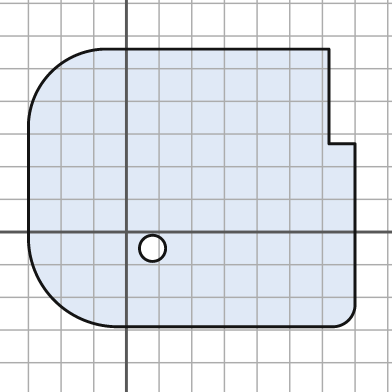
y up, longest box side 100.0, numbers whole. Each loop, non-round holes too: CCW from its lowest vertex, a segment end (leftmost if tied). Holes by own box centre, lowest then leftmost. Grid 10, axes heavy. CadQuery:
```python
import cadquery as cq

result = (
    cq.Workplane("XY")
    .moveTo(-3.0, -29.0)
    .lineTo(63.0, -29.0)
    .threePointArc((68.0, -27.0), (70.0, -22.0))
    .lineTo(70.0, 27.0)
    .lineTo(62.0, 27.0)
    .lineTo(62.0, 56.0)
    .lineTo(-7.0, 56.0)
    .threePointArc((-23.0, 49.0), (-30.0, 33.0))
    .lineTo(-30.0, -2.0)
    .threePointArc((-22.0, -21.0), (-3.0, -29.0))
    .close()
    .moveTo(8.0, -5.0)
    .circle(4.0)
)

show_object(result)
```